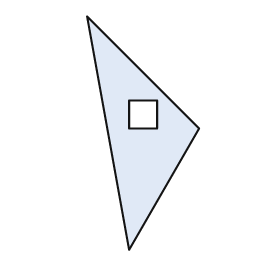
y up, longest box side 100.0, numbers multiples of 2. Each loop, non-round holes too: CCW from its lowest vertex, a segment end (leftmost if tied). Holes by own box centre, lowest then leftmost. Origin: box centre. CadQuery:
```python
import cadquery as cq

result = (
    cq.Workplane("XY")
    .moveTo(-6.0, -50.0)
    .lineTo(24.0, 2.0)
    .lineTo(-24.0, 50.0)
    .close()
    .moveTo(-6.0, 2.0)
    .lineTo(6.0, 2.0)
    .lineTo(6.0, 14.0)
    .lineTo(-6.0, 14.0)
    .close()
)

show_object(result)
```